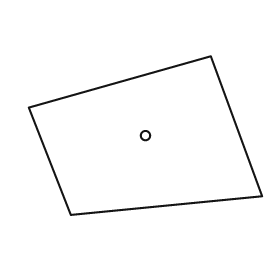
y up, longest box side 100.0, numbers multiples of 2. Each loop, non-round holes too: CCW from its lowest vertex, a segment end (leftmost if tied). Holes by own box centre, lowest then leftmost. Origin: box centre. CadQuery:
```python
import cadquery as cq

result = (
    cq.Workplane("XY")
    .moveTo(-32.0, -34.0)
    .lineTo(50.0, -26.0)
    .lineTo(28.0, 34.0)
    .lineTo(-50.0, 12.0)
    .close()
    .moveTo(0.0, 0.0)
    .circle(2.0)
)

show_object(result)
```